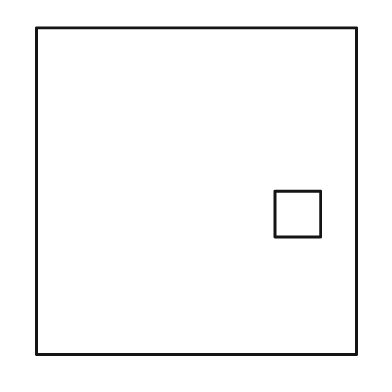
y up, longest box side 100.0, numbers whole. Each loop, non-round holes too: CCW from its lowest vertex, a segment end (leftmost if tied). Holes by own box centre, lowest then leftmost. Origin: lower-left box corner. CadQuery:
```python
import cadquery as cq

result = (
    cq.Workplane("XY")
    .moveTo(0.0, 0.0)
    .lineTo(98.0, 0.0)
    .lineTo(98.0, 100.0)
    .lineTo(0.0, 100.0)
    .close()
    .moveTo(73.0, 36.0)
    .lineTo(87.0, 36.0)
    .lineTo(87.0, 50.0)
    .lineTo(73.0, 50.0)
    .close()
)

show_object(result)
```